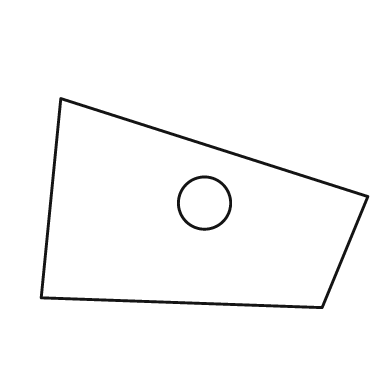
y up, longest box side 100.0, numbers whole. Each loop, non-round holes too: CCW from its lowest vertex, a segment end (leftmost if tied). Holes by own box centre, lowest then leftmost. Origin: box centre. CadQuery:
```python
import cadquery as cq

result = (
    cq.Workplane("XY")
    .moveTo(36.0, -32.0)
    .lineTo(50.0, 2.0)
    .lineTo(-44.0, 32.0)
    .lineTo(-50.0, -29.0)
    .close()
    .moveTo(0.0, 0.0)
    .circle(8.0)
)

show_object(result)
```